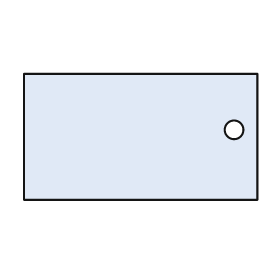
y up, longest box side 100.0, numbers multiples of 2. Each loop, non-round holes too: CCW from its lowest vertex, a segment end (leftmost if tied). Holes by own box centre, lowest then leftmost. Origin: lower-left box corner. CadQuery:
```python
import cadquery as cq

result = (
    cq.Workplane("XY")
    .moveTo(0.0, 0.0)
    .lineTo(100.0, 0.0)
    .lineTo(100.0, 54.0)
    .lineTo(0.0, 54.0)
    .close()
    .moveTo(90.0, 30.0)
    .circle(4.0)
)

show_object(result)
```